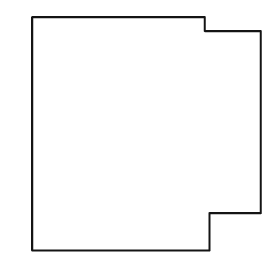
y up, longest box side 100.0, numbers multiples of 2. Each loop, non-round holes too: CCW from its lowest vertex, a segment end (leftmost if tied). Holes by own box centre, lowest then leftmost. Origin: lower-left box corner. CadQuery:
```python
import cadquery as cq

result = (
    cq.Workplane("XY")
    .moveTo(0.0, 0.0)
    .lineTo(76.0, 0.0)
    .lineTo(76.0, 16.0)
    .lineTo(98.0, 16.0)
    .lineTo(98.0, 94.0)
    .lineTo(74.0, 94.0)
    .lineTo(74.0, 100.0)
    .lineTo(0.0, 100.0)
    .close()
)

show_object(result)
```